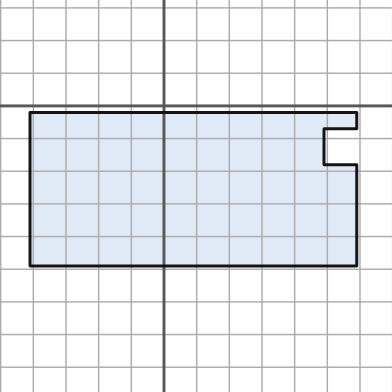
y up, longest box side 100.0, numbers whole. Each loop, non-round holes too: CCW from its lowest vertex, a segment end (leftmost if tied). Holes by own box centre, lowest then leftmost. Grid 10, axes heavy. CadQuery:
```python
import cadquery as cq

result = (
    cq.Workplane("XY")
    .moveTo(-41.0, -49.0)
    .lineTo(59.0, -49.0)
    .lineTo(59.0, -18.0)
    .lineTo(49.0, -18.0)
    .lineTo(49.0, -7.0)
    .lineTo(59.0, -7.0)
    .lineTo(59.0, -2.0)
    .lineTo(-41.0, -2.0)
    .close()
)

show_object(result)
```